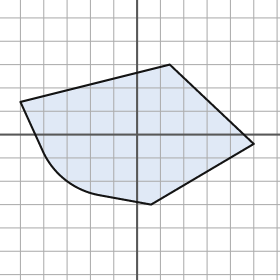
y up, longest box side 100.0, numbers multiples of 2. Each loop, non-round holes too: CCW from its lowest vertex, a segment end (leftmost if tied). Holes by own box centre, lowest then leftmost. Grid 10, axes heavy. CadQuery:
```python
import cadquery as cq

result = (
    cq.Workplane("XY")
    .moveTo(6.0, -30.0)
    .lineTo(50.0, -4.0)
    .lineTo(14.0, 30.0)
    .lineTo(-50.0, 14.0)
    .lineTo(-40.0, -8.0)
    .threePointArc((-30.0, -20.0), (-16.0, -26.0))
    .close()
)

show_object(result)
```